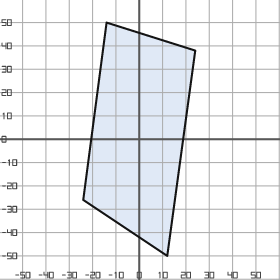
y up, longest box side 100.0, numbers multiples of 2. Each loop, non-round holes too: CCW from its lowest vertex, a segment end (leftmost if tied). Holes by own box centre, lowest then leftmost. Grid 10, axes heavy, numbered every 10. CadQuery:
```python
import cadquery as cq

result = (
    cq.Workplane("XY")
    .moveTo(12.0, -50.0)
    .lineTo(24.0, 38.0)
    .lineTo(-14.0, 50.0)
    .lineTo(-24.0, -26.0)
    .close()
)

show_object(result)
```